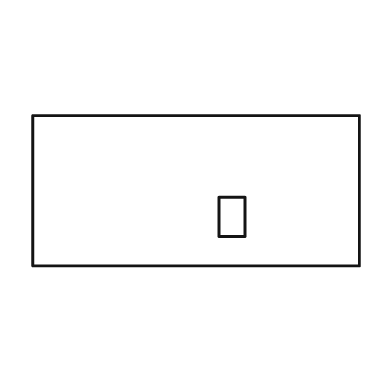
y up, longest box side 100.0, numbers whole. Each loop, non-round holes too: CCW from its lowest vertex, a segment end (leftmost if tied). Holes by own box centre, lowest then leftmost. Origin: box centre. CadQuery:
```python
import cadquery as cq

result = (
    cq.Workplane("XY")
    .moveTo(-50.0, -23.0)
    .lineTo(50.0, -23.0)
    .lineTo(50.0, 23.0)
    .lineTo(-50.0, 23.0)
    .close()
    .moveTo(7.0, -14.0)
    .lineTo(15.0, -14.0)
    .lineTo(15.0, -2.0)
    .lineTo(7.0, -2.0)
    .close()
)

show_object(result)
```